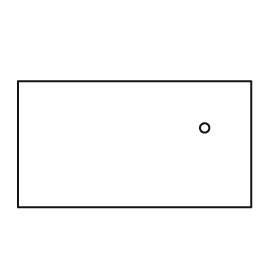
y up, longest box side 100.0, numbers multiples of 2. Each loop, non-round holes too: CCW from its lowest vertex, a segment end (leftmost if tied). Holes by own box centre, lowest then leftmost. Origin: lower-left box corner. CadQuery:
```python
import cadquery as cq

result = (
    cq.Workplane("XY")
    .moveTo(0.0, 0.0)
    .lineTo(100.0, 0.0)
    .lineTo(100.0, 54.0)
    .lineTo(0.0, 54.0)
    .close()
    .moveTo(80.0, 34.0)
    .circle(2.0)
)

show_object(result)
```